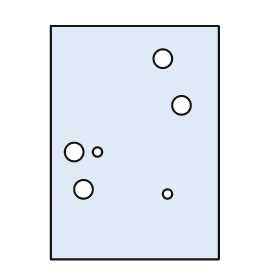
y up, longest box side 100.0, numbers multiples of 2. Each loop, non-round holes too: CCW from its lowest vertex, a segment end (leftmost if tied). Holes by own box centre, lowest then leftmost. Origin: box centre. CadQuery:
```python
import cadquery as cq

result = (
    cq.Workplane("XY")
    .moveTo(-36.0, -50.0)
    .lineTo(36.0, -50.0)
    .lineTo(36.0, 50.0)
    .lineTo(-36.0, 50.0)
    .close()
    .moveTo(14.0, -22.0)
    .circle(2.0)
    .moveTo(-22.0, -20.0)
    .circle(4.0)
    .moveTo(-26.0, -4.0)
    .circle(4.0)
    .moveTo(-16.0, -4.0)
    .circle(2.0)
    .moveTo(20.0, 16.0)
    .circle(4.0)
    .moveTo(12.0, 36.0)
    .circle(4.0)
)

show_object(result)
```